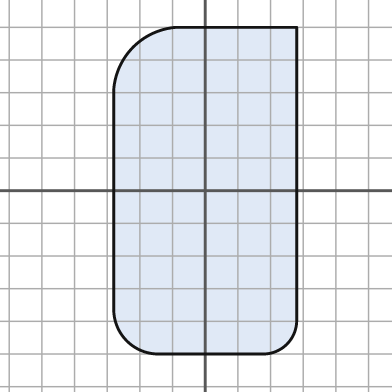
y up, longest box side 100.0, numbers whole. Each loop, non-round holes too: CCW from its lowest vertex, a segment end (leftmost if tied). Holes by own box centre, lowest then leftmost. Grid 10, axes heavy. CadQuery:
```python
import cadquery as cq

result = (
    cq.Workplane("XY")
    .moveTo(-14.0, -50.0)
    .lineTo(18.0, -50.0)
    .threePointArc((25.0, -47.0), (28.0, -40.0))
    .lineTo(28.0, 50.0)
    .lineTo(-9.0, 50.0)
    .threePointArc((-22.0, 44.0), (-28.0, 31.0))
    .lineTo(-28.0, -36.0)
    .threePointArc((-24.0, -46.0), (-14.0, -50.0))
    .close()
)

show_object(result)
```